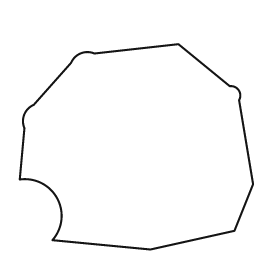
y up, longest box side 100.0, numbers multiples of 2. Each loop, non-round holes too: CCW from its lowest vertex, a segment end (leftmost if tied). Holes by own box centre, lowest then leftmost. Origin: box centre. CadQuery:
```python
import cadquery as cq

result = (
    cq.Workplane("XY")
    .moveTo(6.0, -44.0)
    .lineTo(42.0, -36.0)
    .lineTo(50.0, -16.0)
    .lineTo(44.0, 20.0)
    .threePointArc((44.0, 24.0), (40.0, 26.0))
    .lineTo(18.0, 44.0)
    .lineTo(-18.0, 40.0)
    .threePointArc((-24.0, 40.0), (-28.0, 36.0))
    .lineTo(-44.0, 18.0)
    .threePointArc((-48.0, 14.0), (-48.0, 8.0))
    .lineTo(-50.0, -14.0)
    .threePointArc((-34.0, -22.0), (-36.0, -40.0))
    .close()
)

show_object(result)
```